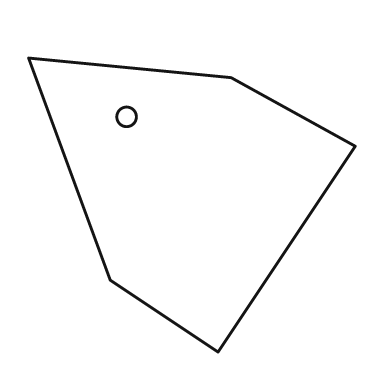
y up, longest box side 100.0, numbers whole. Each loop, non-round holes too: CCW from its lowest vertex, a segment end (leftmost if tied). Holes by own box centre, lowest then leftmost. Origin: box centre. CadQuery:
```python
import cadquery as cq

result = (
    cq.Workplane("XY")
    .moveTo(8.0, -45.0)
    .lineTo(50.0, 18.0)
    .lineTo(12.0, 39.0)
    .lineTo(-50.0, 45.0)
    .lineTo(-25.0, -23.0)
    .close()
    .moveTo(-20.0, 27.0)
    .circle(3.0)
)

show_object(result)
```